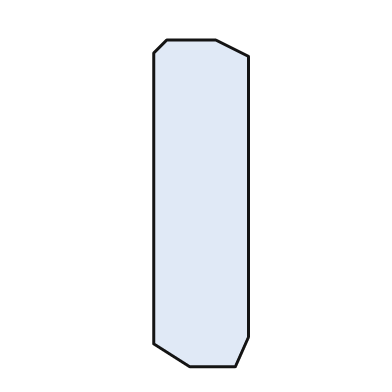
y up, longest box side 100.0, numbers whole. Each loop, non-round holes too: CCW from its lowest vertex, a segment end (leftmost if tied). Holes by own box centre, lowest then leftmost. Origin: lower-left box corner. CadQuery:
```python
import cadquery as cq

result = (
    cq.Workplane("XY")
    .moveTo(11.0, 0.0)
    .lineTo(25.0, 0.0)
    .lineTo(29.0, 9.0)
    .lineTo(29.0, 95.0)
    .lineTo(19.0, 100.0)
    .lineTo(4.0, 100.0)
    .lineTo(0.0, 96.0)
    .lineTo(0.0, 7.0)
    .close()
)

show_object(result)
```